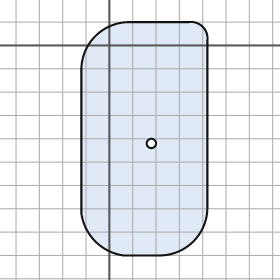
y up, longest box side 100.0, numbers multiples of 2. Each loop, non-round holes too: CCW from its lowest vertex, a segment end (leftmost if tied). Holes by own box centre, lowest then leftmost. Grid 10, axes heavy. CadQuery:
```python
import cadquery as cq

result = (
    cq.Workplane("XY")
    .moveTo(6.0, -90.0)
    .lineTo(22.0, -90.0)
    .threePointArc((36.0, -84.0), (42.0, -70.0))
    .lineTo(42.0, 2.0)
    .threePointArc((40.0, 8.0), (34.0, 10.0))
    .lineTo(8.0, 10.0)
    .threePointArc((-6.0, 4.0), (-12.0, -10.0))
    .lineTo(-12.0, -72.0)
    .threePointArc((-6.0, -84.0), (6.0, -90.0))
    .close()
    .moveTo(18.0, -42.0)
    .circle(2.0)
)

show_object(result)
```